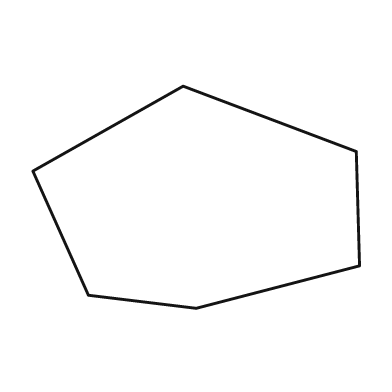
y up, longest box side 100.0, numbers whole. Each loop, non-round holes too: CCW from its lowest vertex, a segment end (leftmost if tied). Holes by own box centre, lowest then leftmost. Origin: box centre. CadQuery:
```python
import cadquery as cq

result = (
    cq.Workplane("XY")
    .moveTo(0.0, -34.0)
    .lineTo(50.0, -21.0)
    .lineTo(49.0, 14.0)
    .lineTo(-4.0, 34.0)
    .lineTo(-50.0, 8.0)
    .lineTo(-33.0, -30.0)
    .close()
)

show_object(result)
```